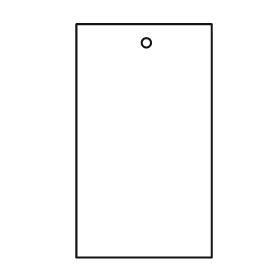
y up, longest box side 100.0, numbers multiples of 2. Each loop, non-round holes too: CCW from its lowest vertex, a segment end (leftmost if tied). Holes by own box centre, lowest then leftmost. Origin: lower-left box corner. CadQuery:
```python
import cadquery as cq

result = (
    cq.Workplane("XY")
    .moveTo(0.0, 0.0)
    .lineTo(58.0, 0.0)
    .lineTo(58.0, 100.0)
    .lineTo(0.0, 100.0)
    .close()
    .moveTo(30.0, 92.0)
    .circle(2.0)
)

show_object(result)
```